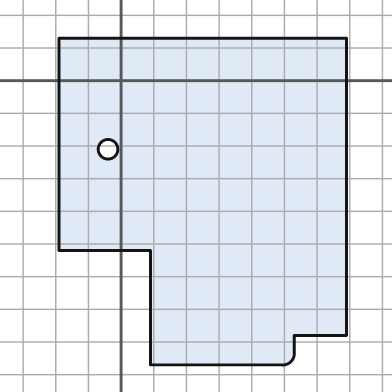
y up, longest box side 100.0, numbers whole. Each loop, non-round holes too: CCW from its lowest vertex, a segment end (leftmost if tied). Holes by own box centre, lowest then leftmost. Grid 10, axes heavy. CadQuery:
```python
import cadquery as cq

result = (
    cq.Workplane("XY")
    .moveTo(9.0, -87.0)
    .lineTo(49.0, -87.0)
    .threePointArc((52.0, -86.0), (53.0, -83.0))
    .lineTo(53.0, -78.0)
    .lineTo(69.0, -78.0)
    .lineTo(69.0, 13.0)
    .lineTo(-19.0, 13.0)
    .lineTo(-19.0, -52.0)
    .lineTo(9.0, -52.0)
    .close()
    .moveTo(-4.0, -21.0)
    .circle(3.0)
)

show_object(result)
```